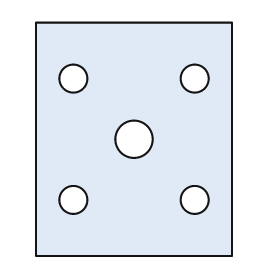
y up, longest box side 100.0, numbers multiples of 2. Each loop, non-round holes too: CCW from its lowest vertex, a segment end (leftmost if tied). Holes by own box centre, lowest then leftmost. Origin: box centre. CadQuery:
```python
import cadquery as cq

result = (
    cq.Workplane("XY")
    .moveTo(-42.0, -50.0)
    .lineTo(42.0, -50.0)
    .lineTo(42.0, 50.0)
    .lineTo(-42.0, 50.0)
    .close()
    .moveTo(-26.0, -26.0)
    .circle(6.0)
    .moveTo(26.0, -26.0)
    .circle(6.0)
    .moveTo(0.0, 0.0)
    .circle(8.0)
    .moveTo(-26.0, 26.0)
    .circle(6.0)
    .moveTo(26.0, 26.0)
    .circle(6.0)
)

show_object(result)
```